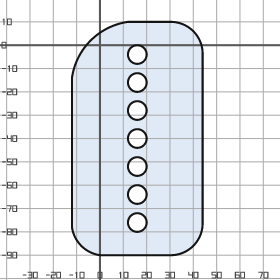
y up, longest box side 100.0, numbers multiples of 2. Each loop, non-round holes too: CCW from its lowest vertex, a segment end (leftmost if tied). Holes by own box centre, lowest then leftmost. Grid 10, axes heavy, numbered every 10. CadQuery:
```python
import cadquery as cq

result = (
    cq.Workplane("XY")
    .moveTo(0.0, -90.0)
    .lineTo(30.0, -90.0)
    .threePointArc((40.0, -86.0), (44.0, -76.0))
    .lineTo(44.0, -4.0)
    .threePointArc((40.0, 6.0), (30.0, 10.0))
    .lineTo(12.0, 10.0)
    .threePointArc((-4.0, 2.0), (-12.0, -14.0))
    .lineTo(-12.0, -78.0)
    .threePointArc((-8.0, -86.0), (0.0, -90.0))
    .close()
    .moveTo(16.0, -76.0)
    .circle(4.0)
    .moveTo(16.0, -64.0)
    .circle(4.0)
    .moveTo(16.0, -52.0)
    .circle(4.0)
    .moveTo(16.0, -40.0)
    .circle(4.0)
    .moveTo(16.0, -28.0)
    .circle(4.0)
    .moveTo(16.0, -16.0)
    .circle(4.0)
    .moveTo(16.0, -4.0)
    .circle(4.0)
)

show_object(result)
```